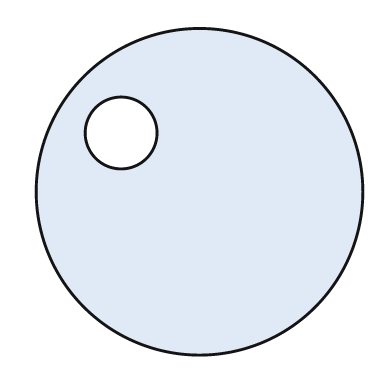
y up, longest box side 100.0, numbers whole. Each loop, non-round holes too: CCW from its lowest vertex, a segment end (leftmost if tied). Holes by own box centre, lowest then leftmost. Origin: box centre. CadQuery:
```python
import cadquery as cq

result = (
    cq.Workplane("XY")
    .moveTo(0.0, 0.0)
    .circle(50.0)
    .moveTo(-24.0, 18.0)
    .circle(11.0)
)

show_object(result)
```